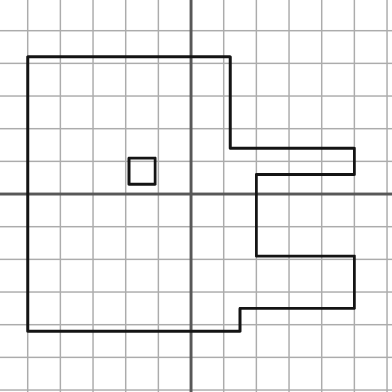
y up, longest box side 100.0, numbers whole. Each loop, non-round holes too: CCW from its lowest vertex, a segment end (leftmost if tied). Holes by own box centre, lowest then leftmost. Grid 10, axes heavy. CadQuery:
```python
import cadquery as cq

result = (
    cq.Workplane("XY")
    .moveTo(-50.0, -42.0)
    .lineTo(15.0, -42.0)
    .lineTo(15.0, -35.0)
    .lineTo(50.0, -35.0)
    .lineTo(50.0, -19.0)
    .lineTo(20.0, -19.0)
    .lineTo(20.0, 6.0)
    .lineTo(50.0, 6.0)
    .lineTo(50.0, 14.0)
    .lineTo(12.0, 14.0)
    .lineTo(12.0, 42.0)
    .lineTo(-50.0, 42.0)
    .close()
    .moveTo(-19.0, 3.0)
    .lineTo(-11.0, 3.0)
    .lineTo(-11.0, 11.0)
    .lineTo(-19.0, 11.0)
    .close()
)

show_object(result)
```